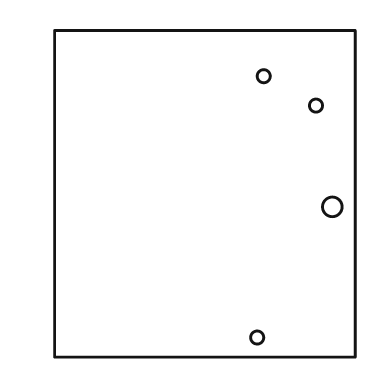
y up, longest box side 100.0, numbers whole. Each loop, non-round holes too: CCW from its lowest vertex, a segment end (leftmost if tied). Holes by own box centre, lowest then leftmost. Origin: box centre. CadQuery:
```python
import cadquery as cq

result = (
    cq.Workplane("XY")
    .moveTo(-46.0, -50.0)
    .lineTo(46.0, -50.0)
    .lineTo(46.0, 50.0)
    .lineTo(-46.0, 50.0)
    .close()
    .moveTo(16.0, -44.0)
    .circle(2.0)
    .moveTo(39.0, -4.0)
    .circle(3.0)
    .moveTo(34.0, 27.0)
    .circle(2.0)
    .moveTo(18.0, 36.0)
    .circle(2.0)
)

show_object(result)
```